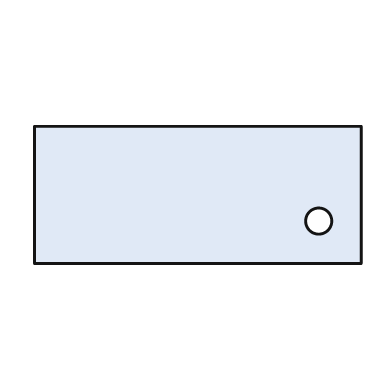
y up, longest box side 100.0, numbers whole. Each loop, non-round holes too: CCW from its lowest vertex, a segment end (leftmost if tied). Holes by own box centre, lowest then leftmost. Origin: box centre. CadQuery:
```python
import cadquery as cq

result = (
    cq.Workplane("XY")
    .moveTo(-50.0, -21.0)
    .lineTo(50.0, -21.0)
    .lineTo(50.0, 21.0)
    .lineTo(-50.0, 21.0)
    .close()
    .moveTo(37.0, -8.0)
    .circle(4.0)
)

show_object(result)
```